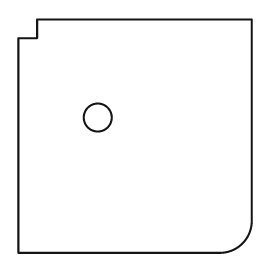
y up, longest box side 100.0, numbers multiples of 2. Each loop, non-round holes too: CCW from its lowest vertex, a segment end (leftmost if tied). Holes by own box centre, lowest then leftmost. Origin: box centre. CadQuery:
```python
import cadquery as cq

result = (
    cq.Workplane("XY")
    .moveTo(-50.0, -50.0)
    .lineTo(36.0, -50.0)
    .threePointArc((46.0, -46.0), (50.0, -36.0))
    .lineTo(50.0, 50.0)
    .lineTo(-42.0, 50.0)
    .lineTo(-42.0, 42.0)
    .lineTo(-50.0, 42.0)
    .close()
    .moveTo(-16.0, 8.0)
    .circle(6.0)
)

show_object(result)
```